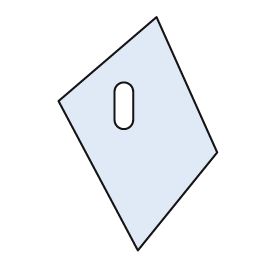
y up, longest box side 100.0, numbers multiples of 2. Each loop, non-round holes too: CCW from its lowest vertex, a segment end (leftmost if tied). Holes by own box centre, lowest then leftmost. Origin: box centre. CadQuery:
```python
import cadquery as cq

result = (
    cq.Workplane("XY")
    .moveTo(0.0, -50.0)
    .lineTo(34.0, -8.0)
    .lineTo(8.0, 50.0)
    .lineTo(-34.0, 14.0)
    .close()
    .moveTo(-10.0, 6.0)
    .threePointArc((-6.0, 2.0), (-2.0, 6.0))
    .lineTo(-2.0, 18.0)
    .threePointArc((-6.0, 22.0), (-10.0, 18.0))
    .close()
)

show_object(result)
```